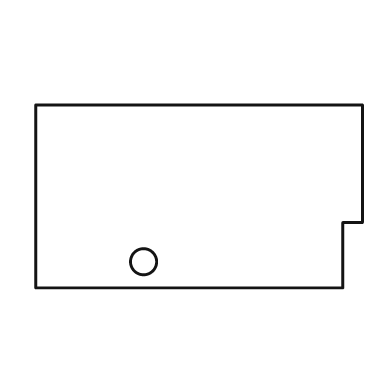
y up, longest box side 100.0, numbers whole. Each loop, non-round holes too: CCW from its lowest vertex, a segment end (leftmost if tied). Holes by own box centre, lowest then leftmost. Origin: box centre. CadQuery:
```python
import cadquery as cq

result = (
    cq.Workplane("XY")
    .moveTo(-50.0, -28.0)
    .lineTo(44.0, -28.0)
    .lineTo(44.0, -8.0)
    .lineTo(50.0, -8.0)
    .lineTo(50.0, 28.0)
    .lineTo(-50.0, 28.0)
    .close()
    .moveTo(-17.0, -20.0)
    .circle(4.0)
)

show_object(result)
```